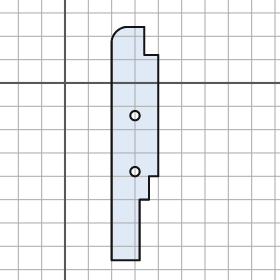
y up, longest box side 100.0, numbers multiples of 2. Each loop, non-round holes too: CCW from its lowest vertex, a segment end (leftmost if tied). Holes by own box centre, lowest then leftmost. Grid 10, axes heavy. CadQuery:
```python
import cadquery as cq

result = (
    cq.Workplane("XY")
    .moveTo(20.0, -76.0)
    .lineTo(32.0, -76.0)
    .lineTo(32.0, -50.0)
    .lineTo(36.0, -50.0)
    .lineTo(36.0, -40.0)
    .lineTo(40.0, -40.0)
    .lineTo(40.0, 12.0)
    .lineTo(34.0, 12.0)
    .lineTo(34.0, 24.0)
    .lineTo(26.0, 24.0)
    .threePointArc((22.0, 22.0), (20.0, 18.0))
    .close()
    .moveTo(30.0, -38.0)
    .circle(2.0)
    .moveTo(30.0, -14.0)
    .circle(2.0)
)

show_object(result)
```